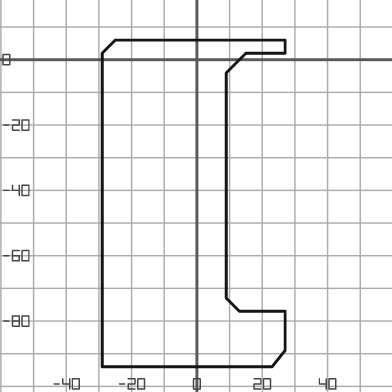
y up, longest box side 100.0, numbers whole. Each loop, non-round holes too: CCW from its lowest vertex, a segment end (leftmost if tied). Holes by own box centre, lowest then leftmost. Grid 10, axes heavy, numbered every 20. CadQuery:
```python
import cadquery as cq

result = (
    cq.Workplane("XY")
    .moveTo(-29.0, -94.0)
    .lineTo(23.0, -94.0)
    .lineTo(27.0, -89.0)
    .lineTo(27.0, -77.0)
    .lineTo(13.0, -77.0)
    .lineTo(9.0, -73.0)
    .lineTo(9.0, -4.0)
    .lineTo(15.0, 2.0)
    .lineTo(27.0, 2.0)
    .lineTo(27.0, 6.0)
    .lineTo(-25.0, 6.0)
    .lineTo(-29.0, 2.0)
    .close()
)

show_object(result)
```